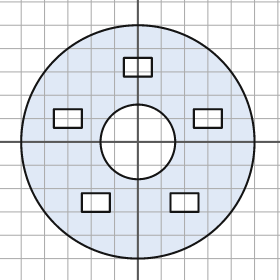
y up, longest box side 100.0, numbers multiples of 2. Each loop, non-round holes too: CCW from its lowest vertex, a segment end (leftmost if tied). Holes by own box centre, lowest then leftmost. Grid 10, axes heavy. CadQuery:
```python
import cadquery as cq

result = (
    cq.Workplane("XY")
    .moveTo(0.0, 0.0)
    .circle(50.0)
    .moveTo(-24.0, -30.0)
    .lineTo(-12.0, -30.0)
    .lineTo(-12.0, -22.0)
    .lineTo(-24.0, -22.0)
    .close()
    .moveTo(14.0, -30.0)
    .lineTo(26.0, -30.0)
    .lineTo(26.0, -22.0)
    .lineTo(14.0, -22.0)
    .close()
    .moveTo(0.0, 0.0)
    .circle(16.0)
    .moveTo(-36.0, 6.0)
    .lineTo(-24.0, 6.0)
    .lineTo(-24.0, 14.0)
    .lineTo(-36.0, 14.0)
    .close()
    .moveTo(24.0, 6.0)
    .lineTo(36.0, 6.0)
    .lineTo(36.0, 14.0)
    .lineTo(24.0, 14.0)
    .close()
    .moveTo(-6.0, 28.0)
    .lineTo(6.0, 28.0)
    .lineTo(6.0, 36.0)
    .lineTo(-6.0, 36.0)
    .close()
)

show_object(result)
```